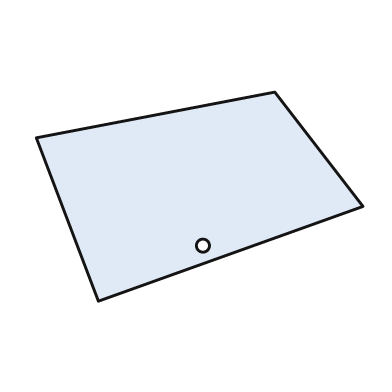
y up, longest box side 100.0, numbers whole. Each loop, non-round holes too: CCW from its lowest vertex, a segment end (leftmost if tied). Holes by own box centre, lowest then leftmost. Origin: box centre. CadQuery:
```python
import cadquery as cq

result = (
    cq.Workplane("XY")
    .moveTo(-31.0, -32.0)
    .lineTo(50.0, -3.0)
    .lineTo(23.0, 32.0)
    .lineTo(-50.0, 18.0)
    .close()
    .moveTo(1.0, -15.0)
    .circle(2.0)
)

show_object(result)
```